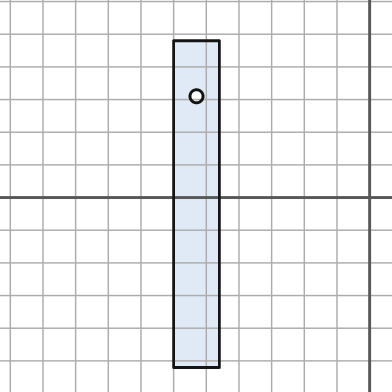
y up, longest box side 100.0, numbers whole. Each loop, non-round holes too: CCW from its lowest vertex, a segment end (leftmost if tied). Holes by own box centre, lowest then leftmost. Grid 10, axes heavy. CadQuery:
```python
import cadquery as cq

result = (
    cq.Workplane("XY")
    .moveTo(-60.0, -52.0)
    .lineTo(-46.0, -52.0)
    .lineTo(-46.0, 48.0)
    .lineTo(-60.0, 48.0)
    .close()
    .moveTo(-53.0, 31.0)
    .circle(2.0)
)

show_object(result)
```